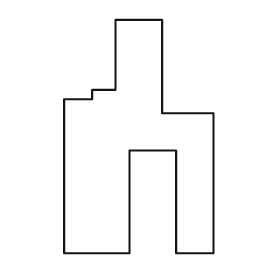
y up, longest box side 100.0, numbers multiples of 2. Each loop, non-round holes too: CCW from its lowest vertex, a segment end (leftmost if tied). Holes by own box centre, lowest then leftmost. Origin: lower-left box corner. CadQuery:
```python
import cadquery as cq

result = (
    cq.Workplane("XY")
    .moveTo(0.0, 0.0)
    .lineTo(28.0, 0.0)
    .lineTo(28.0, 44.0)
    .lineTo(48.0, 44.0)
    .lineTo(48.0, 0.0)
    .lineTo(64.0, 0.0)
    .lineTo(64.0, 60.0)
    .lineTo(42.0, 60.0)
    .lineTo(42.0, 100.0)
    .lineTo(22.0, 100.0)
    .lineTo(22.0, 70.0)
    .lineTo(12.0, 70.0)
    .lineTo(12.0, 66.0)
    .lineTo(0.0, 66.0)
    .close()
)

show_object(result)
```